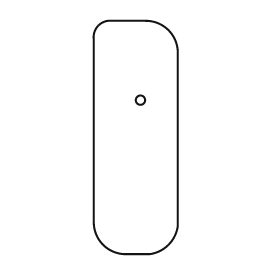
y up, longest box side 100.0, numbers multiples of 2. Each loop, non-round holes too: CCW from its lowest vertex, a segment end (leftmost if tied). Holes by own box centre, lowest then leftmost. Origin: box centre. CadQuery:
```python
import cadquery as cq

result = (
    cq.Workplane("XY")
    .moveTo(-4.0, -50.0)
    .lineTo(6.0, -50.0)
    .threePointArc((14.0, -46.0), (18.0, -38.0))
    .lineTo(18.0, 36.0)
    .threePointArc((14.0, 46.0), (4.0, 50.0))
    .lineTo(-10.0, 50.0)
    .threePointArc((-16.0, 48.0), (-18.0, 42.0))
    .lineTo(-18.0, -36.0)
    .threePointArc((-14.0, -46.0), (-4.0, -50.0))
    .close()
    .moveTo(2.0, 16.0)
    .circle(2.0)
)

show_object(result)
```